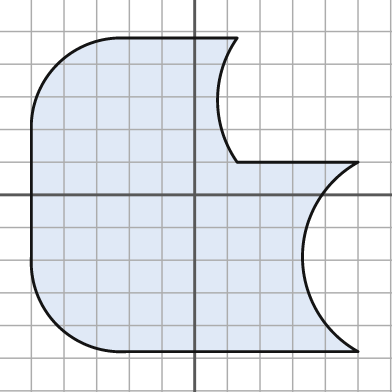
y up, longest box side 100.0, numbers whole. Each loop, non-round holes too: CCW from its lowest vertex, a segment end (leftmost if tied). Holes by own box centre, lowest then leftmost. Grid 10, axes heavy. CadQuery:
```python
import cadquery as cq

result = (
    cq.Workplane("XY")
    .moveTo(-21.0, -48.0)
    .lineTo(50.0, -48.0)
    .threePointArc((33.0, -19.0), (50.0, 10.0))
    .lineTo(13.0, 10.0)
    .threePointArc((7.0, 29.0), (13.0, 48.0))
    .lineTo(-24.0, 48.0)
    .threePointArc((-42.0, 40.0), (-50.0, 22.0))
    .lineTo(-50.0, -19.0)
    .threePointArc((-42.0, -40.0), (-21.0, -48.0))
    .close()
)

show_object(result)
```